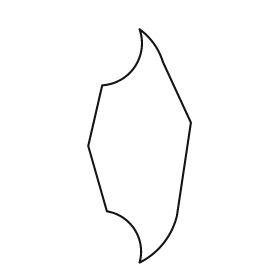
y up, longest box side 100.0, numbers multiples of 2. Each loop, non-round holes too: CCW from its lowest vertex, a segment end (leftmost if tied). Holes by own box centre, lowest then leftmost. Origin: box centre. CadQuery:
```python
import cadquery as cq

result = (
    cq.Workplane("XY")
    .moveTo(0.0, -50.0)
    .threePointArc((10.0, -42.0), (16.0, -30.0))
    .lineTo(22.0, 10.0)
    .lineTo(10.0, 36.0)
    .threePointArc((6.0, 44.0), (0.0, 50.0))
    .threePointArc((-2.0, 34.0), (-16.0, 26.0))
    .lineTo(-22.0, 0.0)
    .lineTo(-14.0, -28.0)
    .threePointArc((-2.0, -36.0), (0.0, -50.0))
    .close()
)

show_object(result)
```